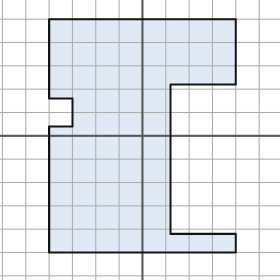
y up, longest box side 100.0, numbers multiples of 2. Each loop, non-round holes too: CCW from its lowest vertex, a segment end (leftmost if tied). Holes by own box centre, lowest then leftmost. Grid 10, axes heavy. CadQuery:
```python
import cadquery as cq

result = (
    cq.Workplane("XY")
    .moveTo(-40.0, -50.0)
    .lineTo(40.0, -50.0)
    .lineTo(40.0, -42.0)
    .lineTo(12.0, -42.0)
    .lineTo(12.0, 22.0)
    .lineTo(40.0, 22.0)
    .lineTo(40.0, 50.0)
    .lineTo(-40.0, 50.0)
    .lineTo(-40.0, 16.0)
    .lineTo(-30.0, 16.0)
    .lineTo(-30.0, 4.0)
    .lineTo(-40.0, 4.0)
    .close()
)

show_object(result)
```